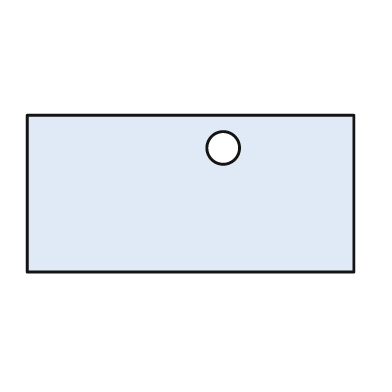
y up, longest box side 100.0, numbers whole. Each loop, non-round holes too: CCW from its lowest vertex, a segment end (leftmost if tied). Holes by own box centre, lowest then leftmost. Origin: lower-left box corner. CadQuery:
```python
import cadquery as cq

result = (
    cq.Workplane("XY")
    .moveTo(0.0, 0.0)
    .lineTo(100.0, 0.0)
    .lineTo(100.0, 48.0)
    .lineTo(0.0, 48.0)
    .close()
    .moveTo(60.0, 38.0)
    .circle(5.0)
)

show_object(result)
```